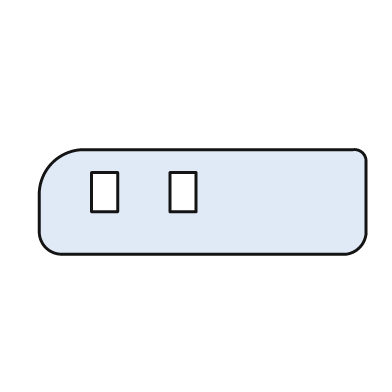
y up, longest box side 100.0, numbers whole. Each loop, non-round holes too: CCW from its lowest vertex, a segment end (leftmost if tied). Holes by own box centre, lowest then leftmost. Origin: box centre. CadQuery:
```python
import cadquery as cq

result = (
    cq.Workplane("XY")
    .moveTo(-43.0, -16.0)
    .lineTo(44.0, -16.0)
    .threePointArc((48.0, -14.0), (50.0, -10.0))
    .lineTo(50.0, 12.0)
    .threePointArc((49.0, 15.0), (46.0, 16.0))
    .lineTo(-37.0, 16.0)
    .threePointArc((-46.0, 12.0), (-50.0, 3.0))
    .lineTo(-50.0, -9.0)
    .threePointArc((-48.0, -14.0), (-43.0, -16.0))
    .close()
    .moveTo(-34.0, -3.0)
    .lineTo(-26.0, -3.0)
    .lineTo(-26.0, 9.0)
    .lineTo(-34.0, 9.0)
    .close()
    .moveTo(-10.0, -3.0)
    .lineTo(-2.0, -3.0)
    .lineTo(-2.0, 9.0)
    .lineTo(-10.0, 9.0)
    .close()
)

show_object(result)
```